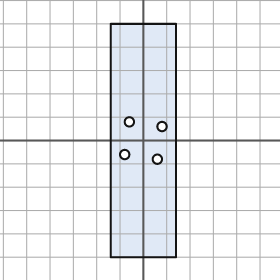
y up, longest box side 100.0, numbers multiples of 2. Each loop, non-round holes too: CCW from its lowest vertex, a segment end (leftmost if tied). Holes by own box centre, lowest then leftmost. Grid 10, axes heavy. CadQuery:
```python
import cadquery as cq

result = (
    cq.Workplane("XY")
    .moveTo(-14.0, -50.0)
    .lineTo(14.0, -50.0)
    .lineTo(14.0, 50.0)
    .lineTo(-14.0, 50.0)
    .close()
    .moveTo(6.0, -8.0)
    .circle(2.0)
    .moveTo(-8.0, -6.0)
    .circle(2.0)
    .moveTo(8.0, 6.0)
    .circle(2.0)
    .moveTo(-6.0, 8.0)
    .circle(2.0)
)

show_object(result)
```